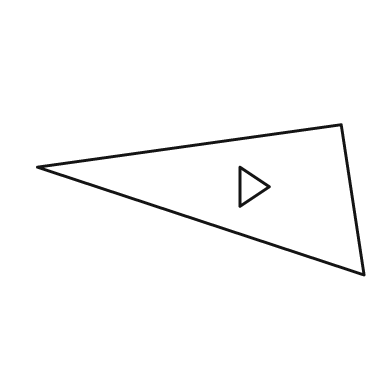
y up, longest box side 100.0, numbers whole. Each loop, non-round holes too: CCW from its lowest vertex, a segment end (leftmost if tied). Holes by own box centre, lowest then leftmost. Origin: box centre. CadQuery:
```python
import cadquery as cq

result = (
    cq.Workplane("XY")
    .moveTo(50.0, -23.0)
    .lineTo(43.0, 23.0)
    .lineTo(-50.0, 10.0)
    .close()
    .moveTo(12.0, -2.0)
    .lineTo(21.0, 4.0)
    .lineTo(12.0, 10.0)
    .close()
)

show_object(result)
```